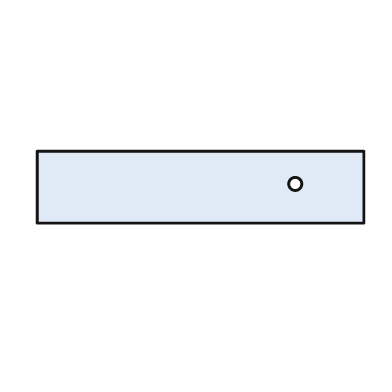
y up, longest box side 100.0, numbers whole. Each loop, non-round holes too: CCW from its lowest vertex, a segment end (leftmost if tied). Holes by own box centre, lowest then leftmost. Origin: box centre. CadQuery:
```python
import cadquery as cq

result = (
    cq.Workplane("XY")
    .moveTo(-50.0, -11.0)
    .lineTo(50.0, -11.0)
    .lineTo(50.0, 11.0)
    .lineTo(-50.0, 11.0)
    .close()
    .moveTo(29.0, 1.0)
    .circle(2.0)
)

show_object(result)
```